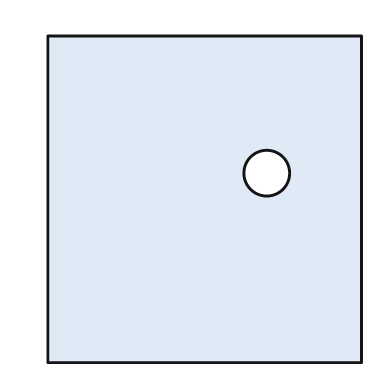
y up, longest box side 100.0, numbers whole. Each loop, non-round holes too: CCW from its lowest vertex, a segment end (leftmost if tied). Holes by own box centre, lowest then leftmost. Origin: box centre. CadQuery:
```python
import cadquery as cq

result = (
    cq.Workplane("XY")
    .moveTo(-48.0, -50.0)
    .lineTo(48.0, -50.0)
    .lineTo(48.0, 50.0)
    .lineTo(-48.0, 50.0)
    .close()
    .moveTo(19.0, 8.0)
    .circle(7.0)
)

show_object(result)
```